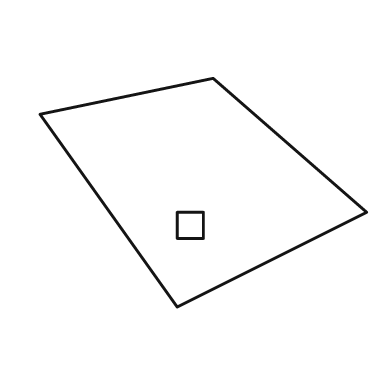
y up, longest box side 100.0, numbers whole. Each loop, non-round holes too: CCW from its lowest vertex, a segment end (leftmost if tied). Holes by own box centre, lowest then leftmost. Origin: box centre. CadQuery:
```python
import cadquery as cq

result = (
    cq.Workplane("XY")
    .moveTo(-8.0, -35.0)
    .lineTo(50.0, -6.0)
    .lineTo(3.0, 35.0)
    .lineTo(-50.0, 24.0)
    .close()
    .moveTo(-8.0, -14.0)
    .lineTo(0.0, -14.0)
    .lineTo(0.0, -6.0)
    .lineTo(-8.0, -6.0)
    .close()
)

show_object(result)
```